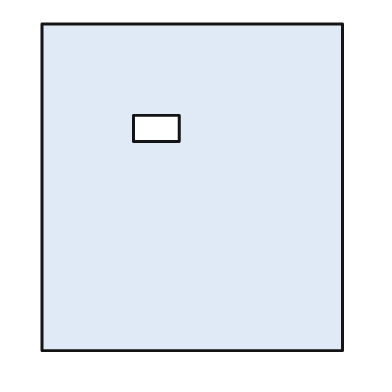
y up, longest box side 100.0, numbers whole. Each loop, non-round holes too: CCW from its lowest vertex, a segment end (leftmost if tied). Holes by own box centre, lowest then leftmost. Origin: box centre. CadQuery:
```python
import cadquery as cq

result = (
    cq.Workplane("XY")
    .moveTo(-46.0, -50.0)
    .lineTo(46.0, -50.0)
    .lineTo(46.0, 50.0)
    .lineTo(-46.0, 50.0)
    .close()
    .moveTo(-18.0, 14.0)
    .lineTo(-4.0, 14.0)
    .lineTo(-4.0, 22.0)
    .lineTo(-18.0, 22.0)
    .close()
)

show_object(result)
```